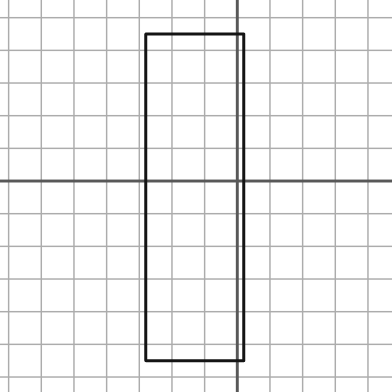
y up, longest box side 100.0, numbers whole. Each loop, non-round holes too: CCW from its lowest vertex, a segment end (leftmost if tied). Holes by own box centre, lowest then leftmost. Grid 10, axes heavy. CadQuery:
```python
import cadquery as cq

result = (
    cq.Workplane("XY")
    .moveTo(-28.0, -55.0)
    .lineTo(2.0, -55.0)
    .lineTo(2.0, 45.0)
    .lineTo(-28.0, 45.0)
    .close()
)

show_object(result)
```